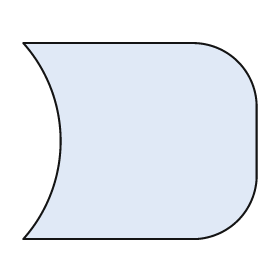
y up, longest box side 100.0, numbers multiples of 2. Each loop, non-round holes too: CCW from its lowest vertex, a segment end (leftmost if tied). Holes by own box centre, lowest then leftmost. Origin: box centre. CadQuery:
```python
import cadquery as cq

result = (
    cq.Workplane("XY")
    .moveTo(-50.0, -42.0)
    .lineTo(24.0, -42.0)
    .threePointArc((42.0, -34.0), (50.0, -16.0))
    .lineTo(50.0, 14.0)
    .threePointArc((42.0, 34.0), (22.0, 42.0))
    .lineTo(-50.0, 42.0)
    .threePointArc((-34.0, 0.0), (-50.0, -42.0))
    .close()
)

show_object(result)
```